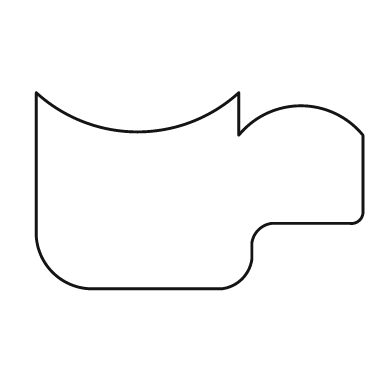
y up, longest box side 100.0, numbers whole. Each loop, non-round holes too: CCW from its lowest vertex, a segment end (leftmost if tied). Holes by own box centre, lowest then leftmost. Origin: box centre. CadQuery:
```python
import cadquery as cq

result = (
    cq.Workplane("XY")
    .moveTo(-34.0, -30.0)
    .lineTo(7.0, -30.0)
    .threePointArc((13.0, -27.0), (16.0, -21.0))
    .lineTo(16.0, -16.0)
    .threePointArc((18.0, -12.0), (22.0, -10.0))
    .lineTo(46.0, -10.0)
    .threePointArc((49.0, -9.0), (50.0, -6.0))
    .lineTo(50.0, 17.0)
    .threePointArc((31.0, 26.0), (12.0, 17.0))
    .lineTo(12.0, 30.0)
    .threePointArc((-19.0, 18.0), (-50.0, 30.0))
    .lineTo(-50.0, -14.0)
    .threePointArc((-45.0, -25.0), (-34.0, -30.0))
    .close()
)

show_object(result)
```